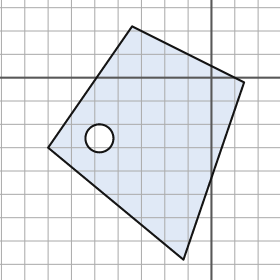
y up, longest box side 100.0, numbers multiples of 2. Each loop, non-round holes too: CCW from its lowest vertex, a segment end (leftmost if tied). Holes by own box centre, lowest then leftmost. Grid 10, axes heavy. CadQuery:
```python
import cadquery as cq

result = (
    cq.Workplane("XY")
    .moveTo(-12.0, -78.0)
    .lineTo(14.0, -2.0)
    .lineTo(-34.0, 22.0)
    .lineTo(-70.0, -30.0)
    .close()
    .moveTo(-48.0, -26.0)
    .circle(6.0)
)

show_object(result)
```